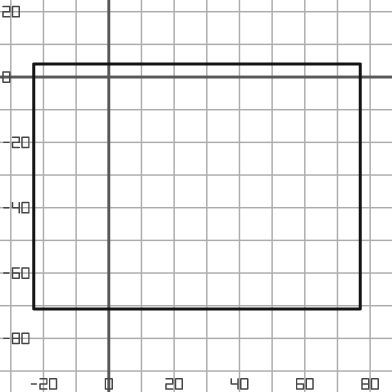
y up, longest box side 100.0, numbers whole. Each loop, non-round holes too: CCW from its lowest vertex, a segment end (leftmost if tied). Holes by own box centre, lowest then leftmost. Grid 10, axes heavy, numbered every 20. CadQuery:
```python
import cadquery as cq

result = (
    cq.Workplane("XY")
    .moveTo(-23.0, -71.0)
    .lineTo(77.0, -71.0)
    .lineTo(77.0, 4.0)
    .lineTo(-23.0, 4.0)
    .close()
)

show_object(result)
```